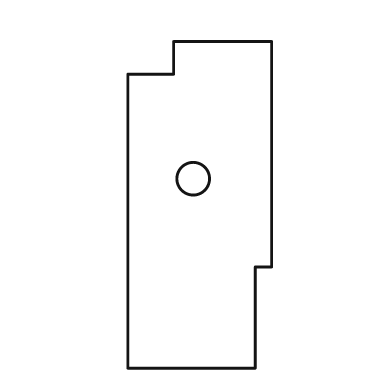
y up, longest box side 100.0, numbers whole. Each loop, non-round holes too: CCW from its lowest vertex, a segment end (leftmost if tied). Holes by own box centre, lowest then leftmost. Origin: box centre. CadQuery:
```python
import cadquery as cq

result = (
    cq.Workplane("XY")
    .moveTo(-22.0, -50.0)
    .lineTo(17.0, -50.0)
    .lineTo(17.0, -19.0)
    .lineTo(22.0, -19.0)
    .lineTo(22.0, 50.0)
    .lineTo(-8.0, 50.0)
    .lineTo(-8.0, 40.0)
    .lineTo(-22.0, 40.0)
    .close()
    .moveTo(-2.0, 8.0)
    .circle(5.0)
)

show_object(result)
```